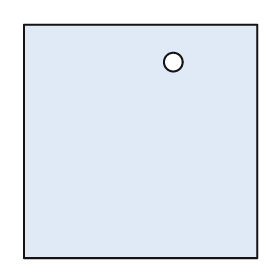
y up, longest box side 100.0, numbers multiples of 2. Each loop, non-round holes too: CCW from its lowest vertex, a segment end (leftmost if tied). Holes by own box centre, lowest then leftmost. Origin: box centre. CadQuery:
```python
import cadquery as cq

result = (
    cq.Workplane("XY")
    .moveTo(-50.0, -50.0)
    .lineTo(50.0, -50.0)
    .lineTo(50.0, 50.0)
    .lineTo(-50.0, 50.0)
    .close()
    .moveTo(14.0, 34.0)
    .circle(4.0)
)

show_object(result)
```